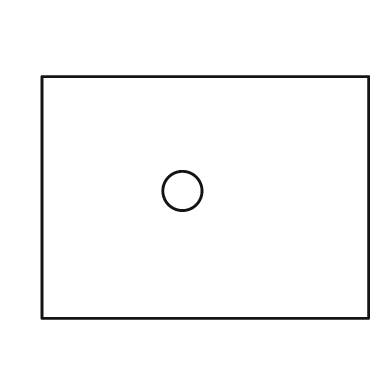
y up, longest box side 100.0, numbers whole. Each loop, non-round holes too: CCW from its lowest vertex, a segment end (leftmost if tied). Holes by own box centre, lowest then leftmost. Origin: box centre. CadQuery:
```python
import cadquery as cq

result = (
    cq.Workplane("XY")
    .moveTo(-50.0, -37.0)
    .lineTo(50.0, -37.0)
    .lineTo(50.0, 37.0)
    .lineTo(-50.0, 37.0)
    .close()
    .moveTo(-7.0, 2.0)
    .circle(6.0)
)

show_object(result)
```